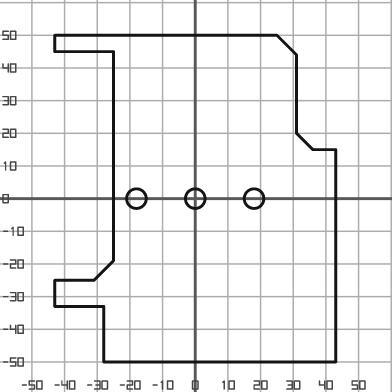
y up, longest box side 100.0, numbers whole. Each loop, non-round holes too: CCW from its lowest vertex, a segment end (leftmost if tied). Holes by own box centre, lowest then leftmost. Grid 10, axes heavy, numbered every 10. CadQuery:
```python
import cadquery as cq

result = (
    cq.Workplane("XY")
    .moveTo(-28.0, -50.0)
    .lineTo(43.0, -50.0)
    .lineTo(43.0, 15.0)
    .lineTo(36.0, 15.0)
    .lineTo(31.0, 20.0)
    .lineTo(31.0, 44.0)
    .lineTo(25.0, 50.0)
    .lineTo(-43.0, 50.0)
    .lineTo(-43.0, 45.0)
    .lineTo(-25.0, 45.0)
    .lineTo(-25.0, -19.0)
    .lineTo(-31.0, -25.0)
    .lineTo(-43.0, -25.0)
    .lineTo(-43.0, -33.0)
    .lineTo(-28.0, -33.0)
    .close()
    .moveTo(-18.0, 0.0)
    .circle(3.0)
    .moveTo(0.0, 0.0)
    .circle(3.0)
    .moveTo(18.0, 0.0)
    .circle(3.0)
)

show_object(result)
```